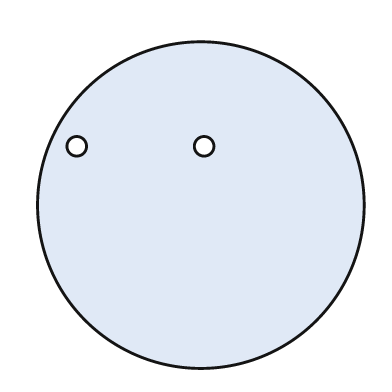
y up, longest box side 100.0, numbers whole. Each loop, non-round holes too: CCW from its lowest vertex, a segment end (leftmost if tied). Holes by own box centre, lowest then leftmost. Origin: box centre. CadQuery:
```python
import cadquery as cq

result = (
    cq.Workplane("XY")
    .moveTo(0.0, 0.0)
    .circle(50.0)
    .moveTo(-38.0, 18.0)
    .circle(3.0)
    .moveTo(1.0, 18.0)
    .circle(3.0)
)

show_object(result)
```